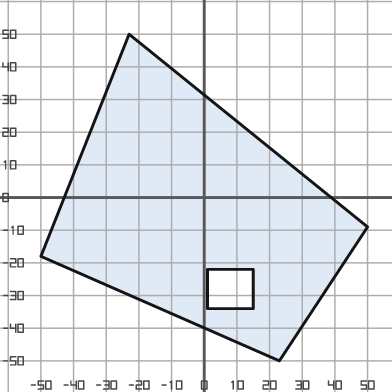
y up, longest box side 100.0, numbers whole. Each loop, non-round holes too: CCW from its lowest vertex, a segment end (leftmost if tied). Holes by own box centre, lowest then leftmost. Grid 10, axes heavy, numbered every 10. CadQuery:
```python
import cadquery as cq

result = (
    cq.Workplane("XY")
    .moveTo(23.0, -50.0)
    .lineTo(50.0, -9.0)
    .lineTo(-23.0, 50.0)
    .lineTo(-50.0, -18.0)
    .close()
    .moveTo(1.0, -34.0)
    .lineTo(15.0, -34.0)
    .lineTo(15.0, -22.0)
    .lineTo(1.0, -22.0)
    .close()
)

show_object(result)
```